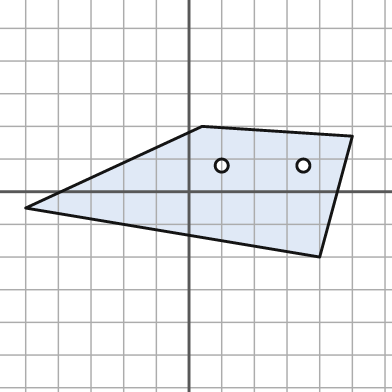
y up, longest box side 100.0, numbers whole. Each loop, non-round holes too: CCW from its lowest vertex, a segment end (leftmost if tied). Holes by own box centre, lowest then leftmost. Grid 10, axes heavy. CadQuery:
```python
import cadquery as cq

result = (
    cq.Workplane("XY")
    .moveTo(40.0, -20.0)
    .lineTo(50.0, 17.0)
    .lineTo(4.0, 20.0)
    .lineTo(-50.0, -5.0)
    .close()
    .moveTo(10.0, 8.0)
    .circle(2.0)
    .moveTo(35.0, 8.0)
    .circle(2.0)
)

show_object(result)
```